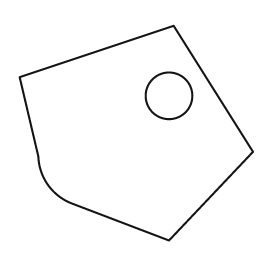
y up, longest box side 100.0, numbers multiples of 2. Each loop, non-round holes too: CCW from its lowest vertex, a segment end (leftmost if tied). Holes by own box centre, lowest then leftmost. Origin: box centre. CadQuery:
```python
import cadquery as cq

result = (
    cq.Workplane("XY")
    .moveTo(14.0, -46.0)
    .lineTo(50.0, -8.0)
    .lineTo(16.0, 46.0)
    .lineTo(-50.0, 24.0)
    .lineTo(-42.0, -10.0)
    .threePointArc((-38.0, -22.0), (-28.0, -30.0))
    .close()
    .moveTo(14.0, 16.0)
    .circle(10.0)
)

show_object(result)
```